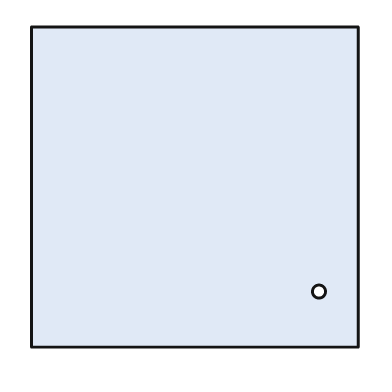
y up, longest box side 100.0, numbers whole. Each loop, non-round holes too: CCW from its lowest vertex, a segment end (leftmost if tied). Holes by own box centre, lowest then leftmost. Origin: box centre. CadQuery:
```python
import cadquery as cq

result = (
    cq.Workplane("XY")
    .moveTo(-50.0, -49.0)
    .lineTo(50.0, -49.0)
    .lineTo(50.0, 49.0)
    .lineTo(-50.0, 49.0)
    .close()
    .moveTo(38.0, -32.0)
    .circle(2.0)
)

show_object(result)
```